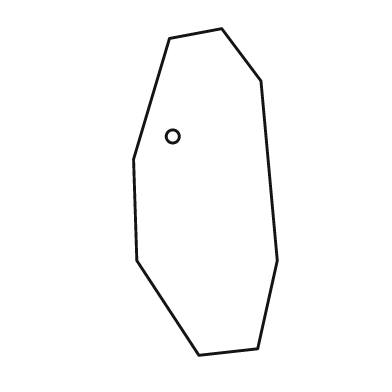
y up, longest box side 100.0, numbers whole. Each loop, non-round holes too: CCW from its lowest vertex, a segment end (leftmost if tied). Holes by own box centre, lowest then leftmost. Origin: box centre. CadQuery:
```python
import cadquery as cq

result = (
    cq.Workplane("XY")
    .moveTo(-2.0, -50.0)
    .lineTo(16.0, -48.0)
    .lineTo(22.0, -21.0)
    .lineTo(17.0, 34.0)
    .lineTo(5.0, 50.0)
    .lineTo(-11.0, 47.0)
    .lineTo(-22.0, 10.0)
    .lineTo(-21.0, -21.0)
    .close()
    .moveTo(-10.0, 17.0)
    .circle(2.0)
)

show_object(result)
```